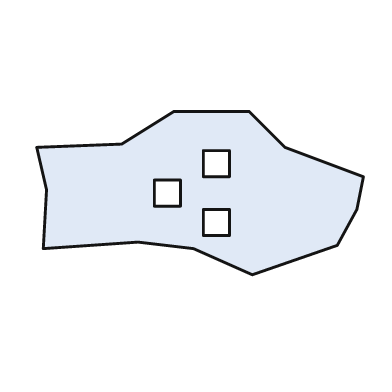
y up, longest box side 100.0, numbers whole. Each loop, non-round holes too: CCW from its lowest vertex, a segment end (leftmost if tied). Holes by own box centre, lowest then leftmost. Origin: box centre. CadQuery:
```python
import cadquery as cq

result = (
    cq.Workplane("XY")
    .moveTo(16.0, -25.0)
    .lineTo(42.0, -16.0)
    .lineTo(48.0, -5.0)
    .lineTo(50.0, 5.0)
    .lineTo(26.0, 14.0)
    .lineTo(15.0, 25.0)
    .lineTo(-8.0, 25.0)
    .lineTo(-24.0, 15.0)
    .lineTo(-50.0, 14.0)
    .lineTo(-47.0, 1.0)
    .lineTo(-48.0, -17.0)
    .lineTo(-19.0, -15.0)
    .lineTo(-2.0, -17.0)
    .close()
    .moveTo(1.0, -13.0)
    .lineTo(9.0, -13.0)
    .lineTo(9.0, -5.0)
    .lineTo(1.0, -5.0)
    .close()
    .moveTo(-14.0, -4.0)
    .lineTo(-6.0, -4.0)
    .lineTo(-6.0, 4.0)
    .lineTo(-14.0, 4.0)
    .close()
    .moveTo(1.0, 5.0)
    .lineTo(9.0, 5.0)
    .lineTo(9.0, 13.0)
    .lineTo(1.0, 13.0)
    .close()
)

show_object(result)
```